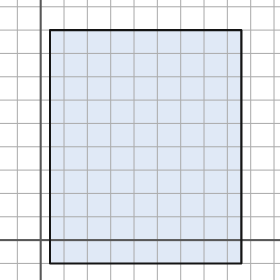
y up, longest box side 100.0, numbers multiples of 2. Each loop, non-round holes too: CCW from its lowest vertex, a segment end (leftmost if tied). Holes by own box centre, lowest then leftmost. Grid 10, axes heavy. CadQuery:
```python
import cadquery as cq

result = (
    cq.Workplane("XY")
    .moveTo(4.0, -10.0)
    .lineTo(86.0, -10.0)
    .lineTo(86.0, 90.0)
    .lineTo(4.0, 90.0)
    .close()
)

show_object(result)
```